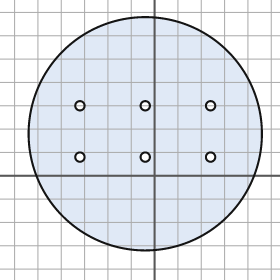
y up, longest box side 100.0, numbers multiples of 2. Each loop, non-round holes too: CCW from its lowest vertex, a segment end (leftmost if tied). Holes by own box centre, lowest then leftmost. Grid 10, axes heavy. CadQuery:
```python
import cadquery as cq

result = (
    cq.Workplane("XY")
    .moveTo(-4.0, 18.0)
    .circle(50.0)
    .moveTo(-32.0, 8.0)
    .circle(2.0)
    .moveTo(-4.0, 8.0)
    .circle(2.0)
    .moveTo(24.0, 8.0)
    .circle(2.0)
    .moveTo(-32.0, 30.0)
    .circle(2.0)
    .moveTo(-4.0, 30.0)
    .circle(2.0)
    .moveTo(24.0, 30.0)
    .circle(2.0)
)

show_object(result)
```